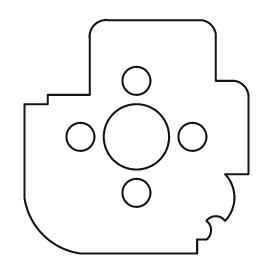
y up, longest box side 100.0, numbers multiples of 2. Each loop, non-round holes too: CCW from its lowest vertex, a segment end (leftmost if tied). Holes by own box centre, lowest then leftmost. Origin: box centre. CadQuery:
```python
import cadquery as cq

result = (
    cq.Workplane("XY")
    .moveTo(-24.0, -50.0)
    .lineTo(26.0, -50.0)
    .lineTo(26.0, -44.0)
    .lineTo(30.0, -44.0)
    .threePointArc((32.0, -40.0), (30.0, -36.0))
    .threePointArc((34.0, -34.0), (38.0, -36.0))
    .threePointArc((42.0, -26.0), (38.0, -16.0))
    .lineTo(48.0, -16.0)
    .lineTo(48.0, 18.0)
    .threePointArc((46.0, 22.0), (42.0, 24.0))
    .lineTo(34.0, 24.0)
    .lineTo(34.0, 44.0)
    .threePointArc((32.0, 48.0), (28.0, 50.0))
    .lineTo(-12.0, 50.0)
    .threePointArc((-18.0, 48.0), (-20.0, 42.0))
    .lineTo(-20.0, 18.0)
    .lineTo(-38.0, 18.0)
    .lineTo(-38.0, 14.0)
    .lineTo(-48.0, 14.0)
    .lineTo(-48.0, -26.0)
    .threePointArc((-40.0, -42.0), (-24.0, -50.0))
    .close()
    .moveTo(0.0, -24.0)
    .circle(6.0)
    .moveTo(-24.0, 0.0)
    .circle(6.0)
    .moveTo(0.0, 0.0)
    .circle(14.0)
    .moveTo(24.0, 0.0)
    .circle(6.0)
    .moveTo(0.0, 24.0)
    .circle(6.0)
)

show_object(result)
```